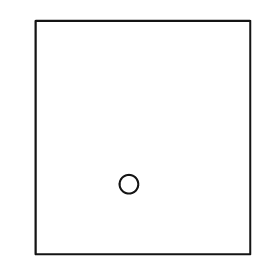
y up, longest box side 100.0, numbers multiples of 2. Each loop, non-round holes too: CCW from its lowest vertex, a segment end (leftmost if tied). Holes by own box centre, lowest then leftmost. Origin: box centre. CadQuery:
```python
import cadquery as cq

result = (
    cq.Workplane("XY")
    .moveTo(-46.0, -50.0)
    .lineTo(46.0, -50.0)
    .lineTo(46.0, 50.0)
    .lineTo(-46.0, 50.0)
    .close()
    .moveTo(-6.0, -20.0)
    .circle(4.0)
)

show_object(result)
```